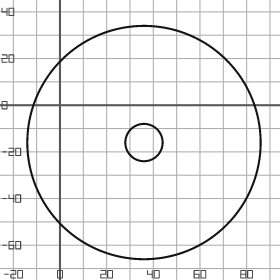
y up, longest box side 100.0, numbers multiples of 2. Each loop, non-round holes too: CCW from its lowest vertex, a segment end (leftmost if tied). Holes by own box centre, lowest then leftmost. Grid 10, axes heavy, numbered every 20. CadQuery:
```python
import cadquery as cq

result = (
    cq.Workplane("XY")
    .moveTo(36.0, -16.0)
    .circle(50.0)
    .moveTo(36.0, -16.0)
    .circle(8.0)
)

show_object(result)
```